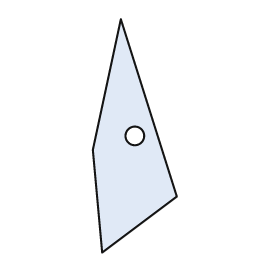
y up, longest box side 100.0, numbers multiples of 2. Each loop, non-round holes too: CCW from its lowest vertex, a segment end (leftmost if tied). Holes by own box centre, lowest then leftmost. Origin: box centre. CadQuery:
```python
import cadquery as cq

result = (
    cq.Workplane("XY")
    .moveTo(-14.0, -50.0)
    .lineTo(18.0, -26.0)
    .lineTo(-6.0, 50.0)
    .lineTo(-18.0, -6.0)
    .close()
    .moveTo(0.0, 0.0)
    .circle(4.0)
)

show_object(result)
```